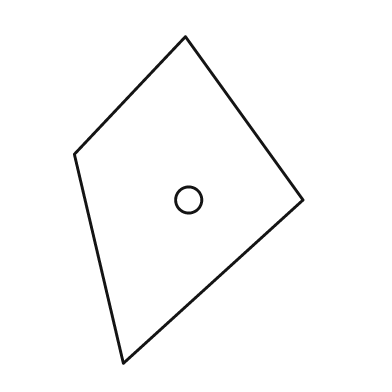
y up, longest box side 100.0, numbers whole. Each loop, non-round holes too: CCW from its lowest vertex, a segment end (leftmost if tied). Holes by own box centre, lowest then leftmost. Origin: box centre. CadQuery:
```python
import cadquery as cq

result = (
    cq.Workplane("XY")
    .moveTo(-20.0, -50.0)
    .lineTo(35.0, 0.0)
    .lineTo(-1.0, 50.0)
    .lineTo(-35.0, 14.0)
    .close()
    .moveTo(0.0, 0.0)
    .circle(4.0)
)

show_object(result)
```